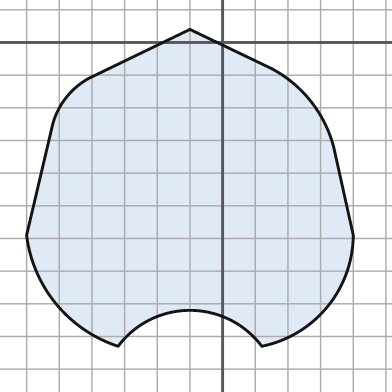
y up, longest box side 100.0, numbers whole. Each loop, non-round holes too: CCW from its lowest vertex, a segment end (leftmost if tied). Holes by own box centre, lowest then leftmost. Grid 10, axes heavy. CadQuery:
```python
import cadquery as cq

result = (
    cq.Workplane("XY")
    .moveTo(-32.0, -93.0)
    .threePointArc((-10.0, -82.0), (12.0, -93.0))
    .threePointArc((32.0, -81.0), (40.0, -59.0))
    .lineTo(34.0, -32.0)
    .threePointArc((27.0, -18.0), (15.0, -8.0))
    .lineTo(-10.0, 4.0)
    .lineTo(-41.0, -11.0)
    .threePointArc((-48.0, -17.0), (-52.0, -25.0))
    .lineTo(-60.0, -59.0)
    .threePointArc((-51.0, -80.0), (-32.0, -93.0))
    .close()
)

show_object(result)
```